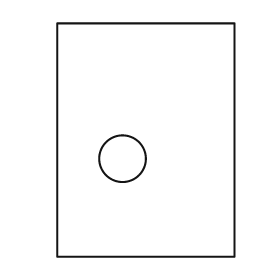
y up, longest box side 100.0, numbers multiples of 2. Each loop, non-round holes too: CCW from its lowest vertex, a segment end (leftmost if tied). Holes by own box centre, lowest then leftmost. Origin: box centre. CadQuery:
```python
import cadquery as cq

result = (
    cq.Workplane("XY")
    .moveTo(-38.0, -50.0)
    .lineTo(38.0, -50.0)
    .lineTo(38.0, 50.0)
    .lineTo(-38.0, 50.0)
    .close()
    .moveTo(-10.0, -8.0)
    .circle(10.0)
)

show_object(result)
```